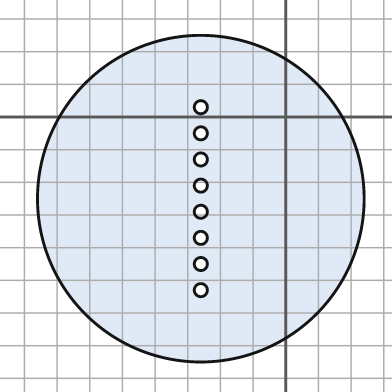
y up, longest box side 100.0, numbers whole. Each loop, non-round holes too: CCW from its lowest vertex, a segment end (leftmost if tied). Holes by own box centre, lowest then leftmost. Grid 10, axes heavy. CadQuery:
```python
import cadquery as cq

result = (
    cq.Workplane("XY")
    .moveTo(-26.0, -25.0)
    .circle(50.0)
    .moveTo(-26.0, -53.0)
    .circle(2.0)
    .moveTo(-26.0, -45.0)
    .circle(2.0)
    .moveTo(-26.0, -37.0)
    .circle(2.0)
    .moveTo(-26.0, -29.0)
    .circle(2.0)
    .moveTo(-26.0, -21.0)
    .circle(2.0)
    .moveTo(-26.0, -13.0)
    .circle(2.0)
    .moveTo(-26.0, -5.0)
    .circle(2.0)
    .moveTo(-26.0, 3.0)
    .circle(2.0)
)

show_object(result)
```